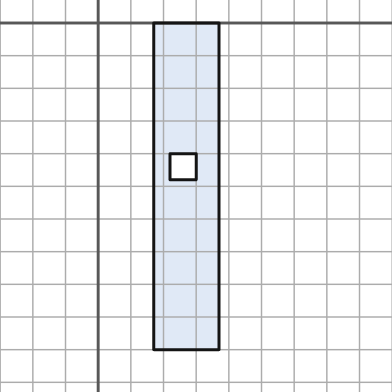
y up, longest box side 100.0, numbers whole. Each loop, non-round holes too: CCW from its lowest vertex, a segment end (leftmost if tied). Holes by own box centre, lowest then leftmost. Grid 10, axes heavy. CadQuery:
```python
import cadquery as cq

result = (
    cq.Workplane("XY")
    .moveTo(17.0, -100.0)
    .lineTo(37.0, -100.0)
    .lineTo(37.0, 0.0)
    .lineTo(17.0, 0.0)
    .close()
    .moveTo(22.0, -48.0)
    .lineTo(30.0, -48.0)
    .lineTo(30.0, -40.0)
    .lineTo(22.0, -40.0)
    .close()
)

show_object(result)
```